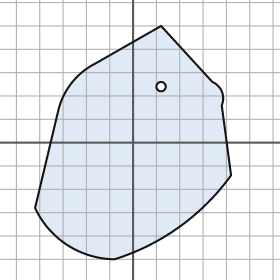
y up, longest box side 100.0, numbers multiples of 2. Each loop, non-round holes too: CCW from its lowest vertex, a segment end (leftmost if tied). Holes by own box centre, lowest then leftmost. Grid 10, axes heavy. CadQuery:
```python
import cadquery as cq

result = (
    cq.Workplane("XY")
    .moveTo(-8.0, -50.0)
    .threePointArc((20.0, -36.0), (42.0, -14.0))
    .lineTo(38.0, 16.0)
    .threePointArc((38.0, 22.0), (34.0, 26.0))
    .lineTo(12.0, 50.0)
    .lineTo(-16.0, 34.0)
    .threePointArc((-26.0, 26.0), (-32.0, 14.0))
    .lineTo(-42.0, -28.0)
    .threePointArc((-28.0, -44.0), (-8.0, -50.0))
    .close()
    .moveTo(12.0, 24.0)
    .circle(2.0)
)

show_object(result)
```